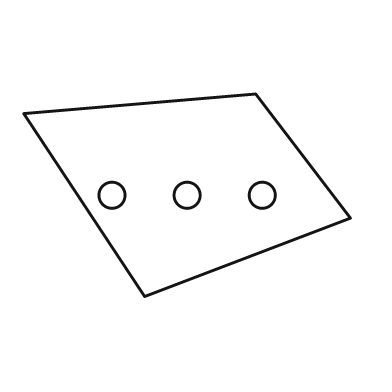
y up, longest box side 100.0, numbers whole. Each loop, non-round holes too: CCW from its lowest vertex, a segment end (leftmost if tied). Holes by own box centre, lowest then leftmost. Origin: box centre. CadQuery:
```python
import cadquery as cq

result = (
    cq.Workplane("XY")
    .moveTo(-13.0, -31.0)
    .lineTo(50.0, -7.0)
    .lineTo(21.0, 31.0)
    .lineTo(-50.0, 25.0)
    .close()
    .moveTo(-23.0, 0.0)
    .circle(4.0)
    .moveTo(0.0, 0.0)
    .circle(4.0)
    .moveTo(23.0, 0.0)
    .circle(4.0)
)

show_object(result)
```